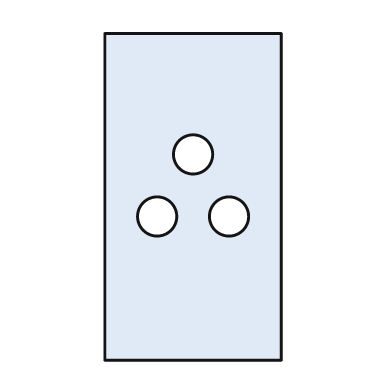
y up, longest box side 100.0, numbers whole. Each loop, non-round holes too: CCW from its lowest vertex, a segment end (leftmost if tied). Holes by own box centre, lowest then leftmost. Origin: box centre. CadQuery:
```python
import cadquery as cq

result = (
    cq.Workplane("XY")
    .moveTo(-27.0, -50.0)
    .lineTo(27.0, -50.0)
    .lineTo(27.0, 50.0)
    .lineTo(-27.0, 50.0)
    .close()
    .moveTo(-11.0, -6.0)
    .circle(6.0)
    .moveTo(11.0, -6.0)
    .circle(6.0)
    .moveTo(0.0, 13.0)
    .circle(6.0)
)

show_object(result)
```